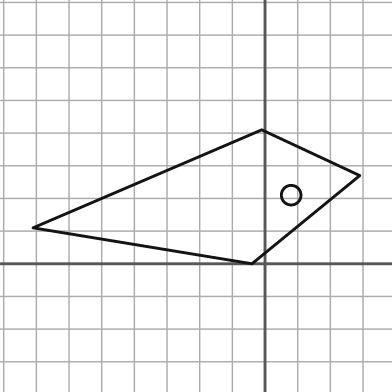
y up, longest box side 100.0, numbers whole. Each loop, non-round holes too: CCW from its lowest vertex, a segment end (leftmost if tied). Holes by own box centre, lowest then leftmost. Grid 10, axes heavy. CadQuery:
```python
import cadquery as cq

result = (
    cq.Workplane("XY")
    .moveTo(-4.0, 0.0)
    .lineTo(29.0, 27.0)
    .lineTo(-1.0, 41.0)
    .lineTo(-71.0, 11.0)
    .close()
    .moveTo(8.0, 21.0)
    .circle(3.0)
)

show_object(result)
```